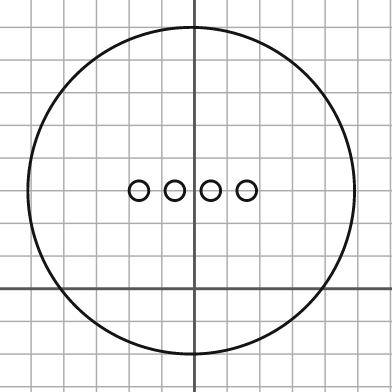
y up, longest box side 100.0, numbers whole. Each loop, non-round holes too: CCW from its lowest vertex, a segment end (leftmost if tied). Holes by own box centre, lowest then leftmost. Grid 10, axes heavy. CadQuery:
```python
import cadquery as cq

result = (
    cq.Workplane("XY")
    .moveTo(-1.0, 30.0)
    .circle(50.0)
    .moveTo(-17.0, 30.0)
    .circle(3.0)
    .moveTo(-6.0, 30.0)
    .circle(3.0)
    .moveTo(5.0, 30.0)
    .circle(3.0)
    .moveTo(16.0, 30.0)
    .circle(3.0)
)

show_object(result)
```